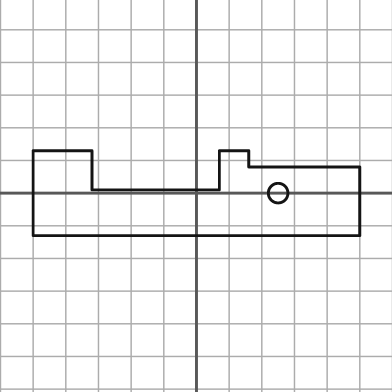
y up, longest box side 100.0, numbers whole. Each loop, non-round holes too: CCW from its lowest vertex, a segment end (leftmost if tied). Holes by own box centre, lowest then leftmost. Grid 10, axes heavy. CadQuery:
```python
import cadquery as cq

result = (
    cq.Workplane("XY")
    .moveTo(-50.0, -13.0)
    .lineTo(50.0, -13.0)
    .lineTo(50.0, 8.0)
    .lineTo(16.0, 8.0)
    .lineTo(16.0, 13.0)
    .lineTo(7.0, 13.0)
    .lineTo(7.0, 1.0)
    .lineTo(-32.0, 1.0)
    .lineTo(-32.0, 13.0)
    .lineTo(-50.0, 13.0)
    .close()
    .moveTo(25.0, 0.0)
    .circle(3.0)
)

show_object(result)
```